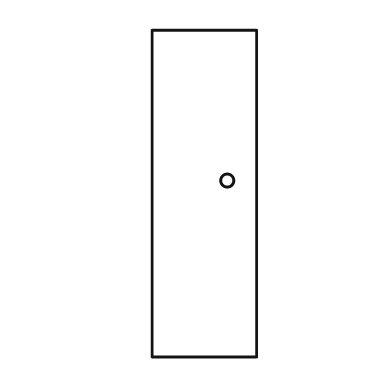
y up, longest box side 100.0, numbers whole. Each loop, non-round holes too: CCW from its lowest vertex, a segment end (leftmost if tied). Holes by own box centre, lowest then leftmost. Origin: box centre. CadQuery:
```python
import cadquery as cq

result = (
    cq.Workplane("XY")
    .moveTo(-16.0, -50.0)
    .lineTo(16.0, -50.0)
    .lineTo(16.0, 50.0)
    .lineTo(-16.0, 50.0)
    .close()
    .moveTo(7.0, 4.0)
    .circle(2.0)
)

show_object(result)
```